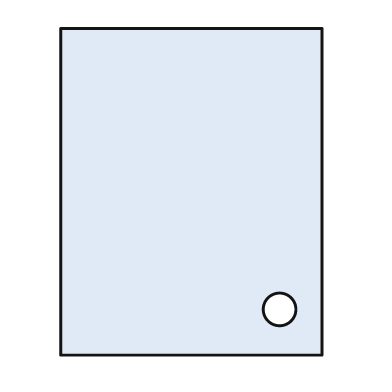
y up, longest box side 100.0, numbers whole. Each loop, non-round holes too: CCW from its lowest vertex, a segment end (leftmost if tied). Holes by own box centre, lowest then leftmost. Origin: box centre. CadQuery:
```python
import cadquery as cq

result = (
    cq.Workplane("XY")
    .moveTo(-40.0, -50.0)
    .lineTo(40.0, -50.0)
    .lineTo(40.0, 50.0)
    .lineTo(-40.0, 50.0)
    .close()
    .moveTo(27.0, -36.0)
    .circle(5.0)
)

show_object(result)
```